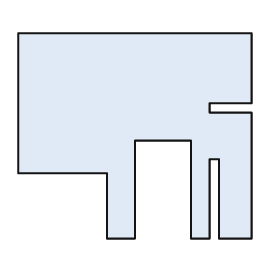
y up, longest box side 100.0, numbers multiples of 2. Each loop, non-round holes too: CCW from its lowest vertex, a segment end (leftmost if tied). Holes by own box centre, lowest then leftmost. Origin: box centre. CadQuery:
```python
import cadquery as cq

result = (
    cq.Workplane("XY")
    .moveTo(-12.0, -44.0)
    .lineTo(0.0, -44.0)
    .lineTo(0.0, -2.0)
    .lineTo(24.0, -2.0)
    .lineTo(24.0, -44.0)
    .lineTo(32.0, -44.0)
    .lineTo(32.0, -10.0)
    .lineTo(36.0, -10.0)
    .lineTo(36.0, -44.0)
    .lineTo(50.0, -44.0)
    .lineTo(50.0, 10.0)
    .lineTo(32.0, 10.0)
    .lineTo(32.0, 14.0)
    .lineTo(50.0, 14.0)
    .lineTo(50.0, 44.0)
    .lineTo(-50.0, 44.0)
    .lineTo(-50.0, -16.0)
    .lineTo(-12.0, -16.0)
    .close()
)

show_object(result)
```